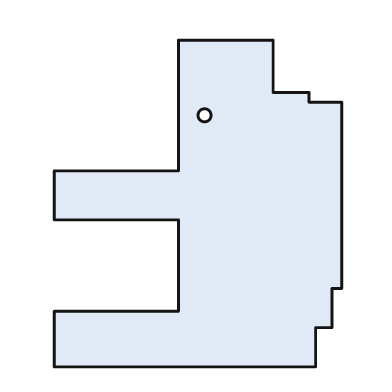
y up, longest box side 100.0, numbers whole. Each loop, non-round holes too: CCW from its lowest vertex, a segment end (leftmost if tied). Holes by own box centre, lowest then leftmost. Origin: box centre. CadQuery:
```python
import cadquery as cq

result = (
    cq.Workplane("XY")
    .moveTo(-44.0, -50.0)
    .lineTo(36.0, -50.0)
    .lineTo(36.0, -38.0)
    .lineTo(41.0, -38.0)
    .lineTo(41.0, -26.0)
    .lineTo(44.0, -26.0)
    .lineTo(44.0, 31.0)
    .lineTo(34.0, 31.0)
    .lineTo(34.0, 34.0)
    .lineTo(23.0, 34.0)
    .lineTo(23.0, 50.0)
    .lineTo(-6.0, 50.0)
    .lineTo(-6.0, 10.0)
    .lineTo(-44.0, 10.0)
    .lineTo(-44.0, -5.0)
    .lineTo(-6.0, -5.0)
    .lineTo(-6.0, -33.0)
    .lineTo(-44.0, -33.0)
    .close()
    .moveTo(2.0, 27.0)
    .circle(2.0)
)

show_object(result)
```